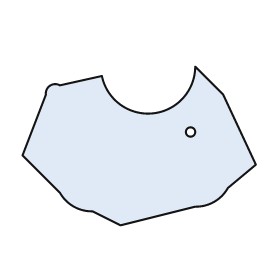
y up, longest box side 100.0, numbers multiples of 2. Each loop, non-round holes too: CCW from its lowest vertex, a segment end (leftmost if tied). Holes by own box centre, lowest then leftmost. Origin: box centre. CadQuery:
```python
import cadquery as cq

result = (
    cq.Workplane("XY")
    .moveTo(-8.0, -34.0)
    .lineTo(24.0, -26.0)
    .threePointArc((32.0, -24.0), (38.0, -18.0))
    .lineTo(50.0, -8.0)
    .lineTo(36.0, 22.0)
    .lineTo(24.0, 34.0)
    .threePointArc((6.0, 14.0), (-16.0, 30.0))
    .lineTo(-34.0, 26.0)
    .threePointArc((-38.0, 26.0), (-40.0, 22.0))
    .lineTo(-50.0, -4.0)
    .lineTo(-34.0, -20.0)
    .threePointArc((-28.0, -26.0), (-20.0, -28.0))
    .close()
    .moveTo(22.0, 6.0)
    .circle(2.0)
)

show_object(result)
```